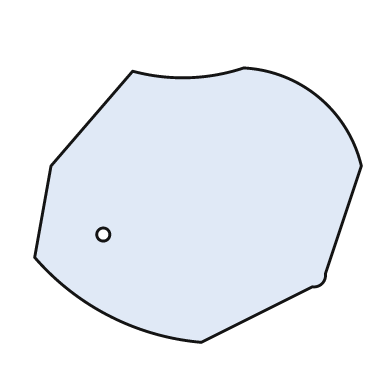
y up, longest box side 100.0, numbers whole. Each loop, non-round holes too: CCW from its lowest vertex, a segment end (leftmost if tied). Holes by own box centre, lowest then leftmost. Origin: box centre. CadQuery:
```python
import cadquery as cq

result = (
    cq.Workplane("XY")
    .moveTo(1.0, -42.0)
    .lineTo(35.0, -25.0)
    .threePointArc((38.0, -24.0), (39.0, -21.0))
    .lineTo(50.0, 12.0)
    .threePointArc((37.0, 33.0), (14.0, 42.0))
    .threePointArc((-3.0, 39.0), (-20.0, 41.0))
    .lineTo(-45.0, 12.0)
    .lineTo(-50.0, -16.0)
    .threePointArc((-27.0, -34.0), (1.0, -42.0))
    .close()
    .moveTo(-29.0, -9.0)
    .circle(2.0)
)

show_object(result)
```